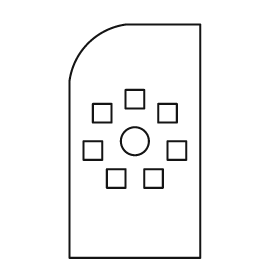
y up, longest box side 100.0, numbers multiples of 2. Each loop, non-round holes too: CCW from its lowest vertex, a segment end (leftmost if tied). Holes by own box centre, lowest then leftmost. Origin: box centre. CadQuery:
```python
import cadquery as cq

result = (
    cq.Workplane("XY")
    .moveTo(-28.0, -50.0)
    .lineTo(28.0, -50.0)
    .lineTo(28.0, 50.0)
    .lineTo(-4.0, 50.0)
    .threePointArc((-20.0, 42.0), (-28.0, 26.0))
    .close()
    .moveTo(-12.0, -20.0)
    .lineTo(-4.0, -20.0)
    .lineTo(-4.0, -12.0)
    .lineTo(-12.0, -12.0)
    .close()
    .moveTo(4.0, -20.0)
    .lineTo(12.0, -20.0)
    .lineTo(12.0, -12.0)
    .lineTo(4.0, -12.0)
    .close()
    .moveTo(-22.0, -8.0)
    .lineTo(-14.0, -8.0)
    .lineTo(-14.0, 0.0)
    .lineTo(-22.0, 0.0)
    .close()
    .moveTo(14.0, -8.0)
    .lineTo(22.0, -8.0)
    .lineTo(22.0, 0.0)
    .lineTo(14.0, 0.0)
    .close()
    .moveTo(0.0, 0.0)
    .circle(6.0)
    .moveTo(-18.0, 8.0)
    .lineTo(-10.0, 8.0)
    .lineTo(-10.0, 16.0)
    .lineTo(-18.0, 16.0)
    .close()
    .moveTo(10.0, 8.0)
    .lineTo(18.0, 8.0)
    .lineTo(18.0, 16.0)
    .lineTo(10.0, 16.0)
    .close()
    .moveTo(-4.0, 14.0)
    .lineTo(4.0, 14.0)
    .lineTo(4.0, 22.0)
    .lineTo(-4.0, 22.0)
    .close()
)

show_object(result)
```